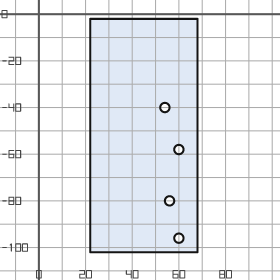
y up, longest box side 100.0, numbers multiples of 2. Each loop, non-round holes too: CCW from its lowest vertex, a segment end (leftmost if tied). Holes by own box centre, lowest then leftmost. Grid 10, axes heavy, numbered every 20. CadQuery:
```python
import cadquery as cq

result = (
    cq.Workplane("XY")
    .moveTo(22.0, -102.0)
    .lineTo(68.0, -102.0)
    .lineTo(68.0, -2.0)
    .lineTo(22.0, -2.0)
    .close()
    .moveTo(60.0, -96.0)
    .circle(2.0)
    .moveTo(56.0, -80.0)
    .circle(2.0)
    .moveTo(60.0, -58.0)
    .circle(2.0)
    .moveTo(54.0, -40.0)
    .circle(2.0)
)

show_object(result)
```